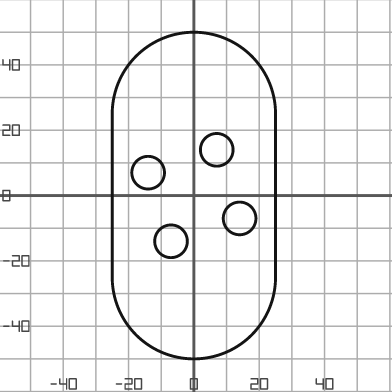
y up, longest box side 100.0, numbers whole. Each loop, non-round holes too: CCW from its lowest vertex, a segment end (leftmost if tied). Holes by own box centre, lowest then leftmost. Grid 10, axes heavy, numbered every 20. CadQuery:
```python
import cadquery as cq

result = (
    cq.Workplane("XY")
    .moveTo(-25.0, -25.0)
    .threePointArc((0.0, -50.0), (25.0, -25.0))
    .lineTo(25.0, 25.0)
    .threePointArc((0.0, 50.0), (-25.0, 25.0))
    .close()
    .moveTo(-7.0, -14.0)
    .circle(5.0)
    .moveTo(14.0, -7.0)
    .circle(5.0)
    .moveTo(-14.0, 7.0)
    .circle(5.0)
    .moveTo(7.0, 14.0)
    .circle(5.0)
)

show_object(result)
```